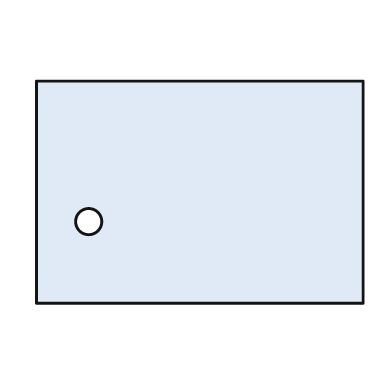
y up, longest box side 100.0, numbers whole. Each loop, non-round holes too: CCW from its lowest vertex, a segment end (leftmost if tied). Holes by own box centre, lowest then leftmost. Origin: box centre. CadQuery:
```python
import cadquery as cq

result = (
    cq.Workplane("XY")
    .moveTo(-50.0, -34.0)
    .lineTo(50.0, -34.0)
    .lineTo(50.0, 34.0)
    .lineTo(-50.0, 34.0)
    .close()
    .moveTo(-34.0, -9.0)
    .circle(4.0)
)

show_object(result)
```